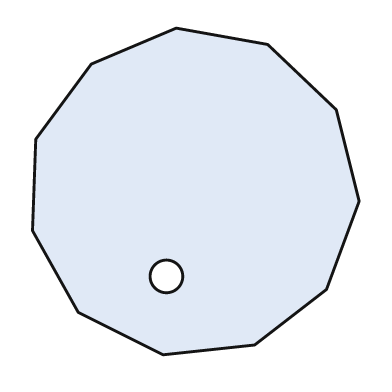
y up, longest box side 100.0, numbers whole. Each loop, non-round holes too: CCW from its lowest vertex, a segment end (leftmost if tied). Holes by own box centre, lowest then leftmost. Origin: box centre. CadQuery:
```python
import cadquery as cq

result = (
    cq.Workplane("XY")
    .moveTo(-10.0, -50.0)
    .lineTo(18.0, -47.0)
    .lineTo(40.0, -30.0)
    .lineTo(50.0, -3.0)
    .lineTo(43.0, 25.0)
    .lineTo(22.0, 45.0)
    .lineTo(-6.0, 50.0)
    .lineTo(-32.0, 39.0)
    .lineTo(-49.0, 16.0)
    .lineTo(-50.0, -12.0)
    .lineTo(-36.0, -37.0)
    .close()
    .moveTo(-9.0, -26.0)
    .circle(5.0)
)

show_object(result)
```